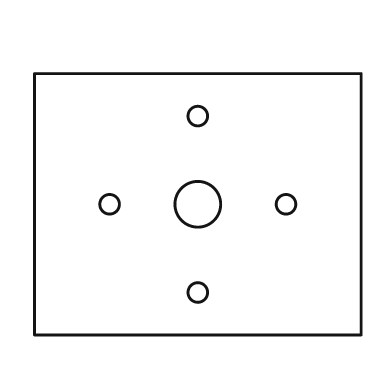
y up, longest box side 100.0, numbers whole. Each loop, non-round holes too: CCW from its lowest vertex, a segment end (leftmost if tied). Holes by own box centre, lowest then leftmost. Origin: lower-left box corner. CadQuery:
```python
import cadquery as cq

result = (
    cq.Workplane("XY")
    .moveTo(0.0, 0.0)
    .lineTo(100.0, 0.0)
    .lineTo(100.0, 80.0)
    .lineTo(0.0, 80.0)
    .close()
    .moveTo(50.0, 13.0)
    .circle(3.0)
    .moveTo(23.0, 40.0)
    .circle(3.0)
    .moveTo(50.0, 40.0)
    .circle(7.0)
    .moveTo(77.0, 40.0)
    .circle(3.0)
    .moveTo(50.0, 67.0)
    .circle(3.0)
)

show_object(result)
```